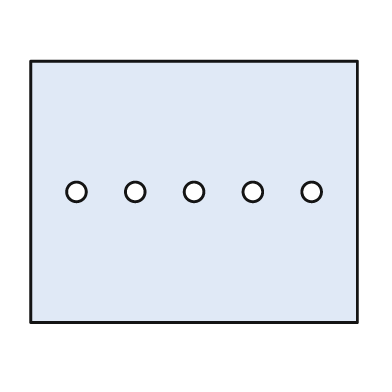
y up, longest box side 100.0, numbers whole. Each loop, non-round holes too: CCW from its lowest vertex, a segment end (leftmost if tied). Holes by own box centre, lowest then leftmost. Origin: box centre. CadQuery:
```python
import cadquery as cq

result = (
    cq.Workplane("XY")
    .moveTo(-50.0, -40.0)
    .lineTo(50.0, -40.0)
    .lineTo(50.0, 40.0)
    .lineTo(-50.0, 40.0)
    .close()
    .moveTo(-36.0, 0.0)
    .circle(3.0)
    .moveTo(-18.0, 0.0)
    .circle(3.0)
    .moveTo(0.0, 0.0)
    .circle(3.0)
    .moveTo(18.0, 0.0)
    .circle(3.0)
    .moveTo(36.0, 0.0)
    .circle(3.0)
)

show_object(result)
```